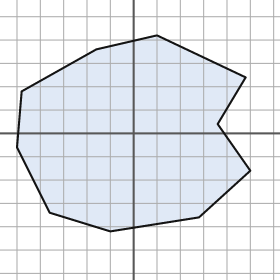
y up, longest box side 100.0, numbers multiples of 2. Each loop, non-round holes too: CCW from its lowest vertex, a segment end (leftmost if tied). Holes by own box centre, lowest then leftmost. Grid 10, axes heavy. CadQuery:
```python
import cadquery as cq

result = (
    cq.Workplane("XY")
    .moveTo(-10.0, -42.0)
    .lineTo(28.0, -36.0)
    .lineTo(50.0, -16.0)
    .lineTo(36.0, 4.0)
    .lineTo(48.0, 24.0)
    .lineTo(10.0, 42.0)
    .lineTo(-16.0, 36.0)
    .lineTo(-48.0, 18.0)
    .lineTo(-50.0, -6.0)
    .lineTo(-36.0, -34.0)
    .close()
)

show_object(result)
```